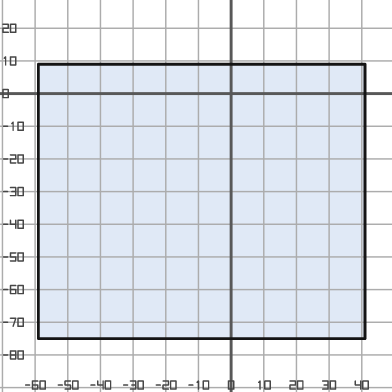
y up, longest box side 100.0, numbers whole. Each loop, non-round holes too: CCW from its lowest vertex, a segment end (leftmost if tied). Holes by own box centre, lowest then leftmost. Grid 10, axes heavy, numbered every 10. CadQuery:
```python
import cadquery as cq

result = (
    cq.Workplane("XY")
    .moveTo(-59.0, -75.0)
    .lineTo(41.0, -75.0)
    .lineTo(41.0, 9.0)
    .lineTo(-59.0, 9.0)
    .close()
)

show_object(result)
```